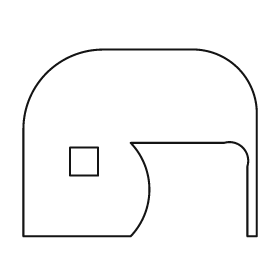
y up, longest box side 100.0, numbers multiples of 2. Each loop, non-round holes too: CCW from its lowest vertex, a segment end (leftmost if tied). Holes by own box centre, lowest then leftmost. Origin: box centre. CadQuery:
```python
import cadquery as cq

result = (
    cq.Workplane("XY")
    .moveTo(-50.0, -40.0)
    .lineTo(-4.0, -40.0)
    .threePointArc((4.0, -20.0), (-4.0, 0.0))
    .lineTo(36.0, 0.0)
    .threePointArc((44.0, -2.0), (46.0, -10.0))
    .lineTo(46.0, -40.0)
    .lineTo(50.0, -40.0)
    .lineTo(50.0, 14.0)
    .threePointArc((42.0, 32.0), (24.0, 40.0))
    .lineTo(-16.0, 40.0)
    .threePointArc((-40.0, 30.0), (-50.0, 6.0))
    .close()
    .moveTo(-30.0, -14.0)
    .lineTo(-18.0, -14.0)
    .lineTo(-18.0, -2.0)
    .lineTo(-30.0, -2.0)
    .close()
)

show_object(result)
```